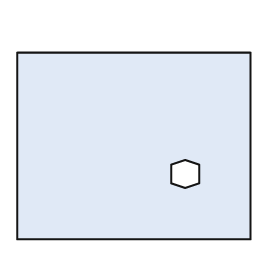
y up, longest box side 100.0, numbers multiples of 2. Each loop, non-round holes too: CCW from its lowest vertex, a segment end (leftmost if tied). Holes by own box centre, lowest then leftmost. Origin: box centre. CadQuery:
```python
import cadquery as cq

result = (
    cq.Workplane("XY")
    .moveTo(-50.0, -40.0)
    .lineTo(50.0, -40.0)
    .lineTo(50.0, 40.0)
    .lineTo(-50.0, 40.0)
    .close()
    .moveTo(22.0, -18.0)
    .lineTo(28.0, -16.0)
    .lineTo(28.0, -8.0)
    .lineTo(22.0, -6.0)
    .lineTo(16.0, -8.0)
    .lineTo(16.0, -16.0)
    .close()
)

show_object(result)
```